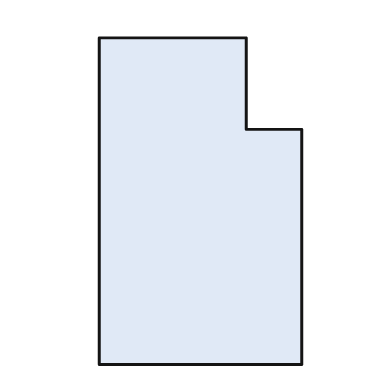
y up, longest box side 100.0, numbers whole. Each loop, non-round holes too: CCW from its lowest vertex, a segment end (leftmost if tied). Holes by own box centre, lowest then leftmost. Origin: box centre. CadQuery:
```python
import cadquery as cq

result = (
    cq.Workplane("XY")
    .moveTo(-31.0, -50.0)
    .lineTo(31.0, -50.0)
    .lineTo(31.0, 22.0)
    .lineTo(14.0, 22.0)
    .lineTo(14.0, 50.0)
    .lineTo(-31.0, 50.0)
    .close()
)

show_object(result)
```